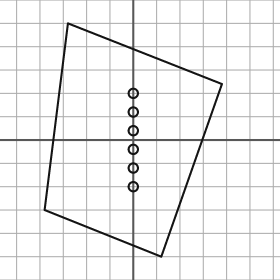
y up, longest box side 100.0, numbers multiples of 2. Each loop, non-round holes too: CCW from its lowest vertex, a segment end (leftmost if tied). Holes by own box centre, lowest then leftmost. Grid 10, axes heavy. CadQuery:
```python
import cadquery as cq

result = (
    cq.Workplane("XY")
    .moveTo(12.0, -50.0)
    .lineTo(38.0, 24.0)
    .lineTo(-28.0, 50.0)
    .lineTo(-38.0, -30.0)
    .close()
    .moveTo(0.0, -20.0)
    .circle(2.0)
    .moveTo(0.0, -12.0)
    .circle(2.0)
    .moveTo(0.0, -4.0)
    .circle(2.0)
    .moveTo(0.0, 4.0)
    .circle(2.0)
    .moveTo(0.0, 12.0)
    .circle(2.0)
    .moveTo(0.0, 20.0)
    .circle(2.0)
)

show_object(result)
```